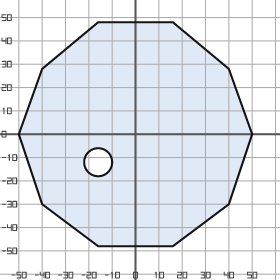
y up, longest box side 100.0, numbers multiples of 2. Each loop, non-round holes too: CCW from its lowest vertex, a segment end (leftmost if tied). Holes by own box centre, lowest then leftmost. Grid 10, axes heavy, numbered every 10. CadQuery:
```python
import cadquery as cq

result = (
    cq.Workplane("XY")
    .moveTo(-16.0, -48.0)
    .lineTo(16.0, -48.0)
    .lineTo(40.0, -30.0)
    .lineTo(50.0, 0.0)
    .lineTo(40.0, 28.0)
    .lineTo(16.0, 48.0)
    .lineTo(-16.0, 48.0)
    .lineTo(-40.0, 28.0)
    .lineTo(-50.0, 0.0)
    .lineTo(-40.0, -30.0)
    .close()
    .moveTo(-16.0, -12.0)
    .circle(6.0)
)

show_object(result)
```